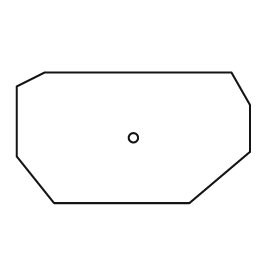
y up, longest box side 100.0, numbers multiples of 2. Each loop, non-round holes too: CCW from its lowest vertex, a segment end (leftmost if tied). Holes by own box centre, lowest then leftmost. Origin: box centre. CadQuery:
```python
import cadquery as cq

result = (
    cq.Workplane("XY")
    .moveTo(-34.0, -28.0)
    .lineTo(24.0, -28.0)
    .lineTo(50.0, -6.0)
    .lineTo(50.0, 14.0)
    .lineTo(42.0, 28.0)
    .lineTo(-38.0, 28.0)
    .lineTo(-50.0, 22.0)
    .lineTo(-50.0, -8.0)
    .close()
    .moveTo(0.0, 0.0)
    .circle(2.0)
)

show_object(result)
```